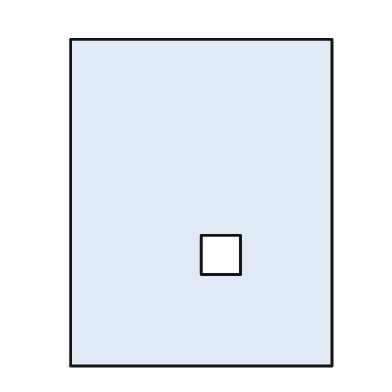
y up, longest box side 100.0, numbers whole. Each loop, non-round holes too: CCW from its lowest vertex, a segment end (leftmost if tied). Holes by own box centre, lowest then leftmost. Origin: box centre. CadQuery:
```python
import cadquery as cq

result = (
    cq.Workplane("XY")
    .moveTo(-40.0, -50.0)
    .lineTo(40.0, -50.0)
    .lineTo(40.0, 50.0)
    .lineTo(-40.0, 50.0)
    .close()
    .moveTo(0.0, -22.0)
    .lineTo(12.0, -22.0)
    .lineTo(12.0, -10.0)
    .lineTo(0.0, -10.0)
    .close()
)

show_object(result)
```